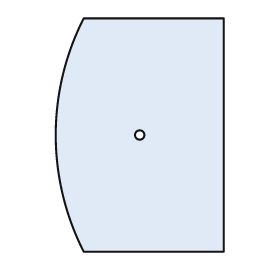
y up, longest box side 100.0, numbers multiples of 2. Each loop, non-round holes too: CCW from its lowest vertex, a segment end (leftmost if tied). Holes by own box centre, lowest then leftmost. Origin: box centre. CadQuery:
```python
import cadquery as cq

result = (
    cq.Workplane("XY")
    .moveTo(-24.0, -50.0)
    .lineTo(36.0, -50.0)
    .lineTo(36.0, 50.0)
    .lineTo(-24.0, 50.0)
    .threePointArc((-36.0, 0.0), (-24.0, -50.0))
    .close()
    .moveTo(0.0, 0.0)
    .circle(2.0)
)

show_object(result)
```